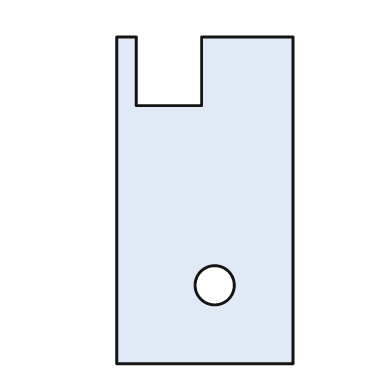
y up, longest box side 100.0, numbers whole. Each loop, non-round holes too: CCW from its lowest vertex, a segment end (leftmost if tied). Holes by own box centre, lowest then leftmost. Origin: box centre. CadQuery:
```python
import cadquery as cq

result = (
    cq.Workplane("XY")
    .moveTo(-27.0, -50.0)
    .lineTo(27.0, -50.0)
    .lineTo(27.0, 50.0)
    .lineTo(-1.0, 50.0)
    .lineTo(-1.0, 29.0)
    .lineTo(-21.0, 29.0)
    .lineTo(-21.0, 50.0)
    .lineTo(-27.0, 50.0)
    .close()
    .moveTo(3.0, -26.0)
    .circle(6.0)
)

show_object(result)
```